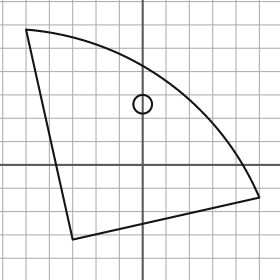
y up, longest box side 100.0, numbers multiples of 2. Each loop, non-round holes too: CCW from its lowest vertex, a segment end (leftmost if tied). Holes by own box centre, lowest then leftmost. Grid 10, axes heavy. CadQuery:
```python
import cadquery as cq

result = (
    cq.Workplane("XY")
    .moveTo(-30.0, -32.0)
    .lineTo(50.0, -14.0)
    .threePointArc((10.0, 36.0), (-50.0, 58.0))
    .close()
    .moveTo(0.0, 26.0)
    .circle(4.0)
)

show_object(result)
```